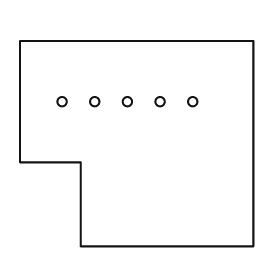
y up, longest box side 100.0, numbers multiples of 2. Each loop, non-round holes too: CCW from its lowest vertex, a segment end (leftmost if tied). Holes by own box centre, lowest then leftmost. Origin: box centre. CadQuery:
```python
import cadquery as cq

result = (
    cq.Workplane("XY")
    .moveTo(-24.0, -44.0)
    .lineTo(50.0, -44.0)
    .lineTo(50.0, 44.0)
    .lineTo(-50.0, 44.0)
    .lineTo(-50.0, -8.0)
    .lineTo(-24.0, -8.0)
    .close()
    .moveTo(-32.0, 18.0)
    .circle(2.0)
    .moveTo(-18.0, 18.0)
    .circle(2.0)
    .moveTo(-4.0, 18.0)
    .circle(2.0)
    .moveTo(10.0, 18.0)
    .circle(2.0)
    .moveTo(24.0, 18.0)
    .circle(2.0)
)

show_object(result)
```